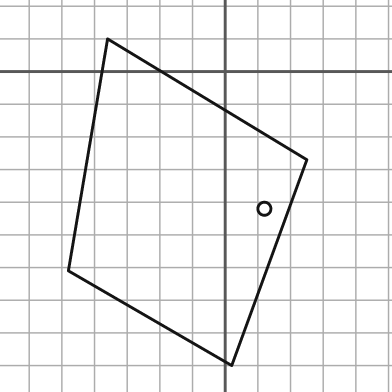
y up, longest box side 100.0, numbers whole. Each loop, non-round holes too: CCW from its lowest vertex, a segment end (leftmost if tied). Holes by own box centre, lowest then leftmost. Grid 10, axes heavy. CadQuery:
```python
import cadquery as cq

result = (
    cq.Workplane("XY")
    .moveTo(2.0, -90.0)
    .lineTo(25.0, -27.0)
    .lineTo(-36.0, 10.0)
    .lineTo(-48.0, -61.0)
    .close()
    .moveTo(12.0, -42.0)
    .circle(2.0)
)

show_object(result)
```